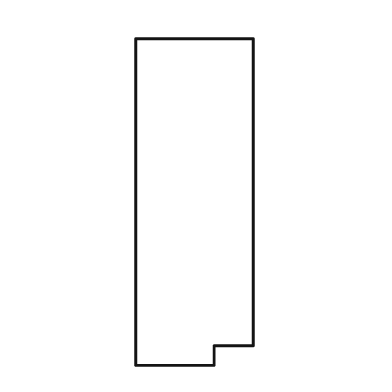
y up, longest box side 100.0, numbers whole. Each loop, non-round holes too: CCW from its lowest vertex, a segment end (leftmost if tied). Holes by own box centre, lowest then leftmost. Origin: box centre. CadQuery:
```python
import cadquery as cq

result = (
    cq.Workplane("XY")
    .moveTo(-18.0, -50.0)
    .lineTo(6.0, -50.0)
    .lineTo(6.0, -44.0)
    .lineTo(18.0, -44.0)
    .lineTo(18.0, 50.0)
    .lineTo(-18.0, 50.0)
    .close()
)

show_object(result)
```